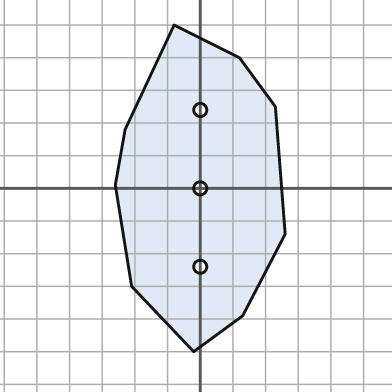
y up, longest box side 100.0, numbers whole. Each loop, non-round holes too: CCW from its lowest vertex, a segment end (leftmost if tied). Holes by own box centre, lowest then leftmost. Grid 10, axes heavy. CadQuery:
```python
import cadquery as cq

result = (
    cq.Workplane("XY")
    .moveTo(-2.0, -50.0)
    .lineTo(13.0, -39.0)
    .lineTo(26.0, -14.0)
    .lineTo(23.0, 25.0)
    .lineTo(12.0, 40.0)
    .lineTo(-8.0, 50.0)
    .lineTo(-23.0, 18.0)
    .lineTo(-26.0, 1.0)
    .lineTo(-21.0, -30.0)
    .close()
    .moveTo(0.0, -24.0)
    .circle(2.0)
    .moveTo(0.0, 0.0)
    .circle(2.0)
    .moveTo(0.0, 24.0)
    .circle(2.0)
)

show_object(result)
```